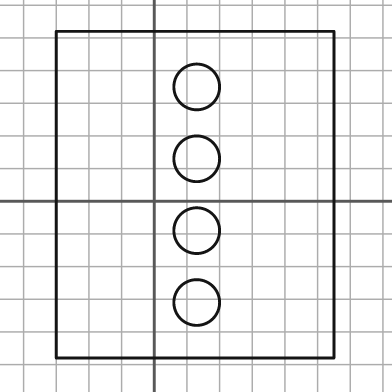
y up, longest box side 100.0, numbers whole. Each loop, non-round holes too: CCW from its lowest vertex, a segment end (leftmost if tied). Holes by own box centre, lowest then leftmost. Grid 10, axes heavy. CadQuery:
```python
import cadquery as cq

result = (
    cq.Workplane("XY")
    .moveTo(-30.0, -48.0)
    .lineTo(55.0, -48.0)
    .lineTo(55.0, 52.0)
    .lineTo(-30.0, 52.0)
    .close()
    .moveTo(13.0, -31.0)
    .circle(7.0)
    .moveTo(13.0, -9.0)
    .circle(7.0)
    .moveTo(13.0, 13.0)
    .circle(7.0)
    .moveTo(13.0, 35.0)
    .circle(7.0)
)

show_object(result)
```